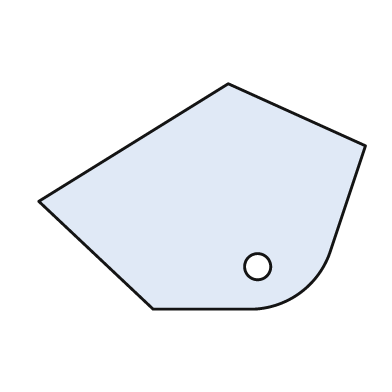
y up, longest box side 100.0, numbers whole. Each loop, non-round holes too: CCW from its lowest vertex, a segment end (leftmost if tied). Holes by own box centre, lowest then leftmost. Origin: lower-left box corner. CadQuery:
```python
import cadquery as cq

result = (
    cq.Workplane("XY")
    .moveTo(35.0, 0.0)
    .lineTo(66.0, 0.0)
    .threePointArc((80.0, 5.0), (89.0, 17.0))
    .lineTo(100.0, 50.0)
    .lineTo(58.0, 69.0)
    .lineTo(0.0, 33.0)
    .close()
    .moveTo(67.0, 13.0)
    .circle(4.0)
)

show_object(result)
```